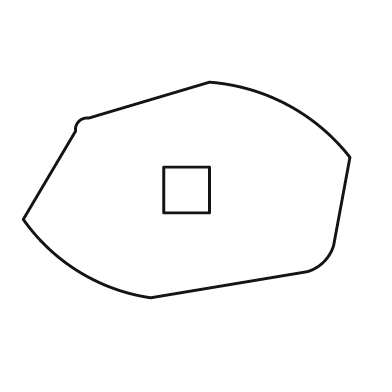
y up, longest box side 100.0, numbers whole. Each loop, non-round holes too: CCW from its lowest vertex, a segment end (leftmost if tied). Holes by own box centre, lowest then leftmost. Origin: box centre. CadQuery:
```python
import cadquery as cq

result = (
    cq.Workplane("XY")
    .moveTo(-11.0, -33.0)
    .lineTo(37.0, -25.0)
    .threePointArc((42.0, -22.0), (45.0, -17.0))
    .lineTo(50.0, 10.0)
    .threePointArc((31.0, 26.0), (7.0, 33.0))
    .lineTo(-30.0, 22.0)
    .threePointArc((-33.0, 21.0), (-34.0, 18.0))
    .lineTo(-50.0, -9.0)
    .threePointArc((-33.0, -25.0), (-11.0, -33.0))
    .close()
    .moveTo(-7.0, -7.0)
    .lineTo(7.0, -7.0)
    .lineTo(7.0, 7.0)
    .lineTo(-7.0, 7.0)
    .close()
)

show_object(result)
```